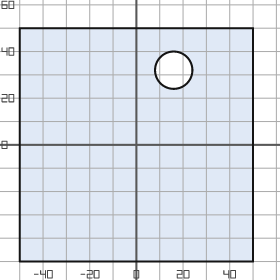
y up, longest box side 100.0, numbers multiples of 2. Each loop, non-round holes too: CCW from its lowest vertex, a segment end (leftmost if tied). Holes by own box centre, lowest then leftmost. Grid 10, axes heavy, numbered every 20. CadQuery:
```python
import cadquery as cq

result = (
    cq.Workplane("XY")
    .moveTo(-50.0, -50.0)
    .lineTo(50.0, -50.0)
    .lineTo(50.0, 50.0)
    .lineTo(-50.0, 50.0)
    .close()
    .moveTo(16.0, 32.0)
    .circle(8.0)
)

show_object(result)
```